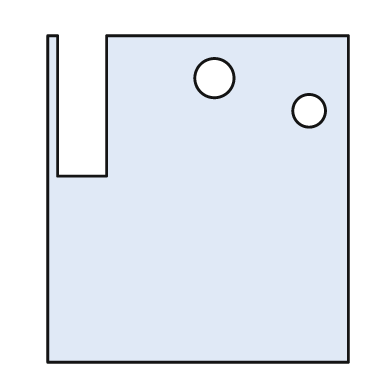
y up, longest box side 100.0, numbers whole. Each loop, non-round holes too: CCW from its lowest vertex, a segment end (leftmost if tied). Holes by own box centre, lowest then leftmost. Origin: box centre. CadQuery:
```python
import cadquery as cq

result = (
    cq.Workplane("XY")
    .moveTo(-46.0, -50.0)
    .lineTo(46.0, -50.0)
    .lineTo(46.0, 50.0)
    .lineTo(-28.0, 50.0)
    .lineTo(-28.0, 7.0)
    .lineTo(-43.0, 7.0)
    .lineTo(-43.0, 50.0)
    .lineTo(-46.0, 50.0)
    .close()
    .moveTo(34.0, 27.0)
    .circle(5.0)
    .moveTo(5.0, 37.0)
    .circle(6.0)
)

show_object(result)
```